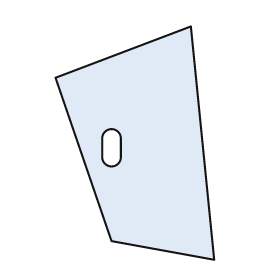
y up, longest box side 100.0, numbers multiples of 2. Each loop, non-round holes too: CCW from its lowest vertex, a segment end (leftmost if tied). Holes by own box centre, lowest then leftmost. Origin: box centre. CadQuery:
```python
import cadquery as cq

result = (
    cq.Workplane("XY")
    .moveTo(34.0, -50.0)
    .lineTo(24.0, 50.0)
    .lineTo(-34.0, 28.0)
    .lineTo(-10.0, -42.0)
    .close()
    .moveTo(-14.0, -6.0)
    .threePointArc((-10.0, -10.0), (-6.0, -6.0))
    .lineTo(-6.0, 2.0)
    .threePointArc((-10.0, 6.0), (-14.0, 2.0))
    .close()
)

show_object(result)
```